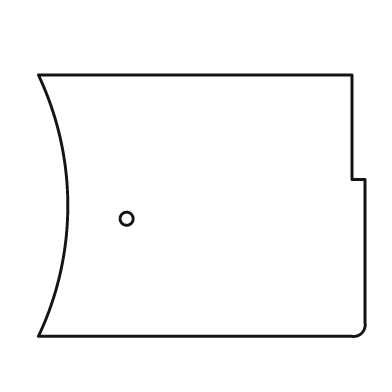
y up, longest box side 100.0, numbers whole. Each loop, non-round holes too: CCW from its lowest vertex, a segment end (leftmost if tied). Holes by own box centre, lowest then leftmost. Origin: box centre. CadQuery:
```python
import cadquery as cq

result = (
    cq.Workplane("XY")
    .moveTo(-50.0, -40.0)
    .lineTo(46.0, -40.0)
    .threePointArc((49.0, -39.0), (50.0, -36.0))
    .lineTo(50.0, 8.0)
    .lineTo(46.0, 8.0)
    .lineTo(46.0, 40.0)
    .lineTo(-50.0, 40.0)
    .threePointArc((-41.0, 0.0), (-50.0, -40.0))
    .close()
    .moveTo(-23.0, -4.0)
    .circle(2.0)
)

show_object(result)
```